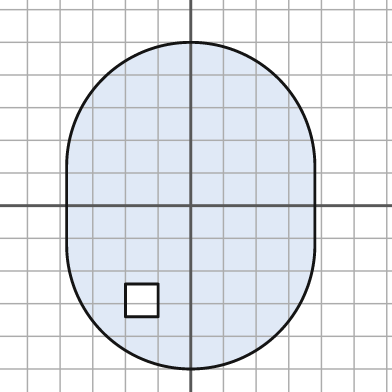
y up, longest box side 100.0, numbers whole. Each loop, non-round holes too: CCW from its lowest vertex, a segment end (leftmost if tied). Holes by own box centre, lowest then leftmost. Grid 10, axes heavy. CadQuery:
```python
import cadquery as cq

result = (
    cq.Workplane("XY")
    .moveTo(-38.0, -12.0)
    .threePointArc((0.0, -50.0), (38.0, -12.0))
    .lineTo(38.0, 12.0)
    .threePointArc((0.0, 50.0), (-38.0, 12.0))
    .close()
    .moveTo(-20.0, -34.0)
    .lineTo(-10.0, -34.0)
    .lineTo(-10.0, -24.0)
    .lineTo(-20.0, -24.0)
    .close()
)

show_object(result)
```